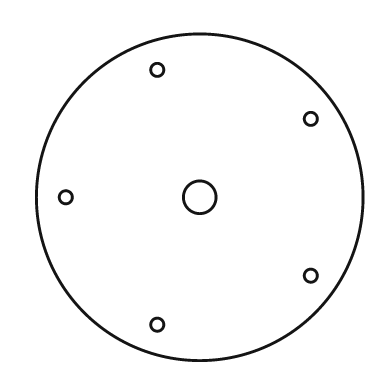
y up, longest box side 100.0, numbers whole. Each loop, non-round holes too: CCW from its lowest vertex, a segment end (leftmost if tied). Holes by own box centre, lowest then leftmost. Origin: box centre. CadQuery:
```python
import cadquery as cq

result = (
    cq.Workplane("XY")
    .moveTo(0.0, 0.0)
    .circle(50.0)
    .moveTo(-13.0, -39.0)
    .circle(2.0)
    .moveTo(34.0, -24.0)
    .circle(2.0)
    .moveTo(-41.0, 0.0)
    .circle(2.0)
    .moveTo(0.0, 0.0)
    .circle(5.0)
    .moveTo(34.0, 24.0)
    .circle(2.0)
    .moveTo(-13.0, 39.0)
    .circle(2.0)
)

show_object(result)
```